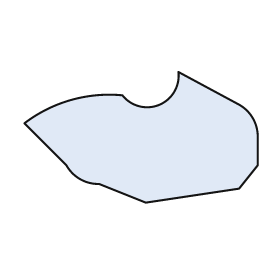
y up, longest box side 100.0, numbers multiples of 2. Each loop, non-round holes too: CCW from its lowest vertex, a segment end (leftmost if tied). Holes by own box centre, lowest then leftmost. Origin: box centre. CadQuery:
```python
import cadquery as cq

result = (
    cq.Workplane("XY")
    .moveTo(2.0, -28.0)
    .lineTo(42.0, -22.0)
    .lineTo(50.0, -12.0)
    .lineTo(50.0, 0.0)
    .threePointArc((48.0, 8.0), (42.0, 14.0))
    .lineTo(16.0, 28.0)
    .threePointArc((8.0, 14.0), (-8.0, 18.0))
    .threePointArc((-30.0, 16.0), (-50.0, 6.0))
    .lineTo(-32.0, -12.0)
    .threePointArc((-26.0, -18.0), (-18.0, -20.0))
    .close()
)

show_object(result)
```